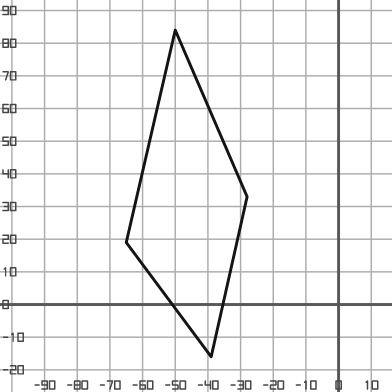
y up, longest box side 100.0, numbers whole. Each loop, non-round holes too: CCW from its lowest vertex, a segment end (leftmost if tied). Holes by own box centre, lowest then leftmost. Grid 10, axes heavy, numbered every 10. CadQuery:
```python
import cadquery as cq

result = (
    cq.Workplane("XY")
    .moveTo(-39.0, -16.0)
    .lineTo(-28.0, 33.0)
    .lineTo(-50.0, 84.0)
    .lineTo(-65.0, 19.0)
    .close()
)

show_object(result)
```